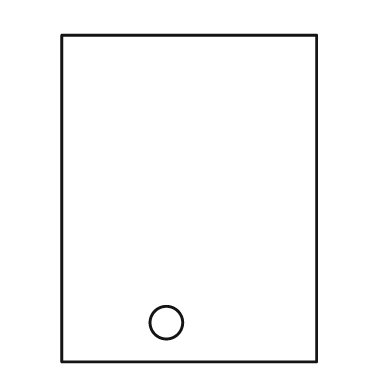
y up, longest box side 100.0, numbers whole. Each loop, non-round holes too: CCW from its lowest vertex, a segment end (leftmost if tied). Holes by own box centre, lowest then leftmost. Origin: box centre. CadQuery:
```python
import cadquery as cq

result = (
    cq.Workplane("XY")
    .moveTo(-39.0, -50.0)
    .lineTo(39.0, -50.0)
    .lineTo(39.0, 50.0)
    .lineTo(-39.0, 50.0)
    .close()
    .moveTo(-7.0, -38.0)
    .circle(5.0)
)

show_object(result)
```